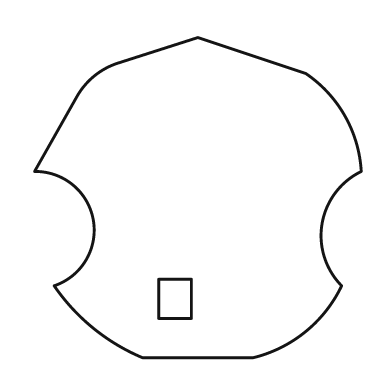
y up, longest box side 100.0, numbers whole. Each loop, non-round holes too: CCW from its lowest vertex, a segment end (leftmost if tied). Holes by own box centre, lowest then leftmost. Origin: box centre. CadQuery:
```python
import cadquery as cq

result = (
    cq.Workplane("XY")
    .moveTo(-17.0, -49.0)
    .lineTo(17.0, -49.0)
    .threePointArc((33.0, -41.0), (44.0, -27.0))
    .threePointArc((38.0, -8.0), (50.0, 8.0))
    .threePointArc((45.0, 25.0), (33.0, 38.0))
    .lineTo(0.0, 49.0)
    .lineTo(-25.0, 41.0)
    .threePointArc((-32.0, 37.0), (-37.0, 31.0))
    .lineTo(-50.0, 8.0)
    .threePointArc((-32.0, -7.0), (-44.0, -27.0))
    .threePointArc((-32.0, -40.0), (-17.0, -49.0))
    .close()
    .moveTo(-12.0, -37.0)
    .lineTo(-2.0, -37.0)
    .lineTo(-2.0, -25.0)
    .lineTo(-12.0, -25.0)
    .close()
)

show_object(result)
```